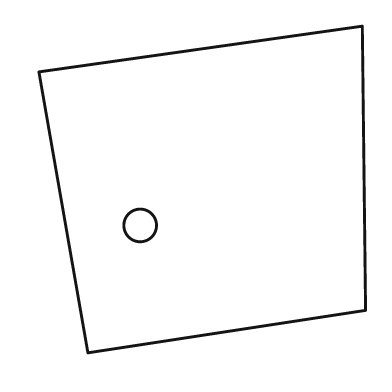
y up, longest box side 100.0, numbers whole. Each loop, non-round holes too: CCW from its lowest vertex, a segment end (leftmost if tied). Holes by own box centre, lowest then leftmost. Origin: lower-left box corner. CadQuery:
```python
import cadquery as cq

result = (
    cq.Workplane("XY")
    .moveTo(15.0, 0.0)
    .lineTo(100.0, 13.0)
    .lineTo(99.0, 100.0)
    .lineTo(0.0, 86.0)
    .close()
    .moveTo(31.0, 39.0)
    .circle(5.0)
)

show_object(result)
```